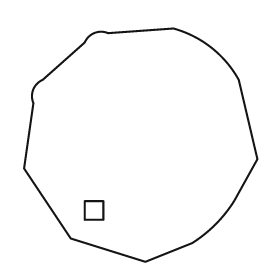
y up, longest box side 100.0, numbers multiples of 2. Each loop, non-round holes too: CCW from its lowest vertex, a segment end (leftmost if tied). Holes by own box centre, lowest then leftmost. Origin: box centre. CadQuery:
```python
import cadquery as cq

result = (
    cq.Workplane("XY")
    .moveTo(2.0, -50.0)
    .lineTo(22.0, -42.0)
    .threePointArc((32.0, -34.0), (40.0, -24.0))
    .lineTo(50.0, -6.0)
    .lineTo(42.0, 28.0)
    .threePointArc((30.0, 42.0), (14.0, 50.0))
    .lineTo(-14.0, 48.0)
    .threePointArc((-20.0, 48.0), (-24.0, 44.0))
    .lineTo(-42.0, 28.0)
    .threePointArc((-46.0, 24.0), (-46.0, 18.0))
    .lineTo(-50.0, -10.0)
    .lineTo(-30.0, -40.0)
    .close()
    .moveTo(-24.0, -32.0)
    .lineTo(-16.0, -32.0)
    .lineTo(-16.0, -24.0)
    .lineTo(-24.0, -24.0)
    .close()
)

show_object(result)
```